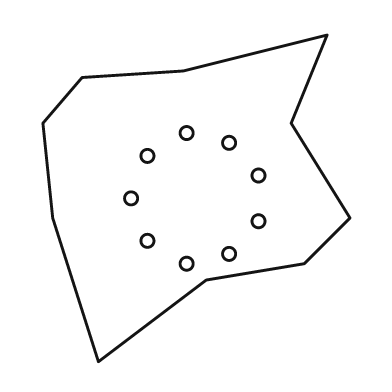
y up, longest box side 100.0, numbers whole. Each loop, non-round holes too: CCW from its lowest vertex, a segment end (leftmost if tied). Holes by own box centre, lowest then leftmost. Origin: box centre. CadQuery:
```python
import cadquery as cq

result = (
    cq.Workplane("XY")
    .moveTo(-30.0, -50.0)
    .lineTo(3.0, -25.0)
    .lineTo(33.0, -20.0)
    .lineTo(47.0, -6.0)
    .lineTo(29.0, 23.0)
    .lineTo(40.0, 50.0)
    .lineTo(-4.0, 39.0)
    .lineTo(-35.0, 37.0)
    .lineTo(-47.0, 23.0)
    .lineTo(-44.0, -6.0)
    .close()
    .moveTo(-3.0, -20.0)
    .circle(2.0)
    .moveTo(10.0, -17.0)
    .circle(2.0)
    .moveTo(-15.0, -13.0)
    .circle(2.0)
    .moveTo(19.0, -7.0)
    .circle(2.0)
    .moveTo(-20.0, 0.0)
    .circle(2.0)
    .moveTo(19.0, 7.0)
    .circle(2.0)
    .moveTo(-15.0, 13.0)
    .circle(2.0)
    .moveTo(10.0, 17.0)
    .circle(2.0)
    .moveTo(-3.0, 20.0)
    .circle(2.0)
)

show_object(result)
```